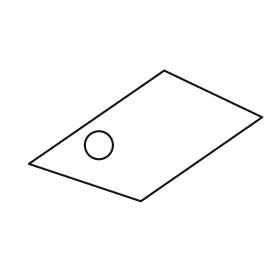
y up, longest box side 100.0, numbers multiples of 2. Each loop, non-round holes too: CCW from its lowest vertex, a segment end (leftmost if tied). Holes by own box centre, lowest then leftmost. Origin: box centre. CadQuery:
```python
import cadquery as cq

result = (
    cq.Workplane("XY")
    .moveTo(-2.0, -28.0)
    .lineTo(50.0, 8.0)
    .lineTo(8.0, 28.0)
    .lineTo(-50.0, -12.0)
    .close()
    .moveTo(-20.0, -4.0)
    .circle(6.0)
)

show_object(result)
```